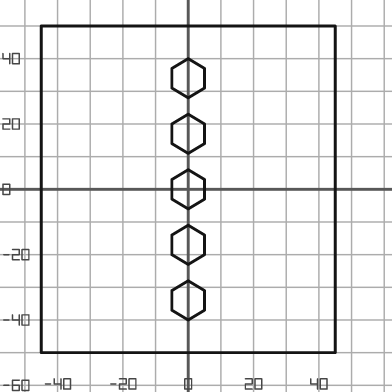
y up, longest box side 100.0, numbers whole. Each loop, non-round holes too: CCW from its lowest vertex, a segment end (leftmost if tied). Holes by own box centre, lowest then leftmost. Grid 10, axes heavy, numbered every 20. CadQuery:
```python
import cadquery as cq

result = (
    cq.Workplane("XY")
    .moveTo(-45.0, -50.0)
    .lineTo(45.0, -50.0)
    .lineTo(45.0, 50.0)
    .lineTo(-45.0, 50.0)
    .close()
    .moveTo(0.0, -40.0)
    .lineTo(5.0, -37.0)
    .lineTo(5.0, -31.0)
    .lineTo(0.0, -28.0)
    .lineTo(-5.0, -31.0)
    .lineTo(-5.0, -37.0)
    .close()
    .moveTo(0.0, -23.0)
    .lineTo(5.0, -20.0)
    .lineTo(5.0, -14.0)
    .lineTo(0.0, -11.0)
    .lineTo(-5.0, -14.0)
    .lineTo(-5.0, -20.0)
    .close()
    .moveTo(0.0, -6.0)
    .lineTo(5.0, -3.0)
    .lineTo(5.0, 3.0)
    .lineTo(0.0, 6.0)
    .lineTo(-5.0, 3.0)
    .lineTo(-5.0, -3.0)
    .close()
    .moveTo(0.0, 11.0)
    .lineTo(5.0, 14.0)
    .lineTo(5.0, 20.0)
    .lineTo(0.0, 23.0)
    .lineTo(-5.0, 20.0)
    .lineTo(-5.0, 14.0)
    .close()
    .moveTo(0.0, 28.0)
    .lineTo(5.0, 31.0)
    .lineTo(5.0, 37.0)
    .lineTo(0.0, 40.0)
    .lineTo(-5.0, 37.0)
    .lineTo(-5.0, 31.0)
    .close()
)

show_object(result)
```